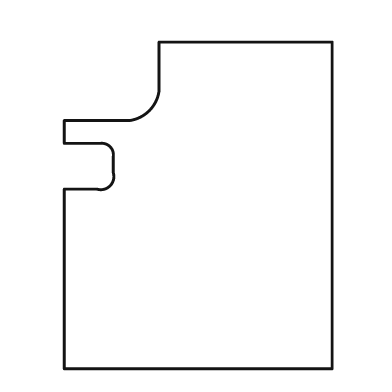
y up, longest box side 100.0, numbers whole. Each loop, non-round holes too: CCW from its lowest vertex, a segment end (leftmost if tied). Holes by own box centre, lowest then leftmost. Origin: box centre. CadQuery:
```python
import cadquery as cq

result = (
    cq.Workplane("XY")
    .moveTo(-41.0, -50.0)
    .lineTo(41.0, -50.0)
    .lineTo(41.0, 50.0)
    .lineTo(-12.0, 50.0)
    .lineTo(-12.0, 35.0)
    .threePointArc((-15.0, 29.0), (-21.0, 26.0))
    .lineTo(-41.0, 26.0)
    .lineTo(-41.0, 19.0)
    .lineTo(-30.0, 19.0)
    .threePointArc((-27.0, 18.0), (-26.0, 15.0))
    .lineTo(-26.0, 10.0)
    .threePointArc((-27.0, 6.0), (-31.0, 5.0))
    .lineTo(-41.0, 5.0)
    .close()
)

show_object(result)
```